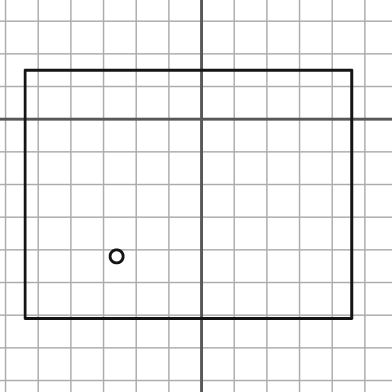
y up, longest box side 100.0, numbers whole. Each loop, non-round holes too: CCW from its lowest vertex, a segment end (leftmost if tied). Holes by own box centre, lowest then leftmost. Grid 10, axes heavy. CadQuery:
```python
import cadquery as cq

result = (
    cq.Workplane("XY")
    .moveTo(-54.0, -61.0)
    .lineTo(46.0, -61.0)
    .lineTo(46.0, 15.0)
    .lineTo(-54.0, 15.0)
    .close()
    .moveTo(-26.0, -42.0)
    .circle(2.0)
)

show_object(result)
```